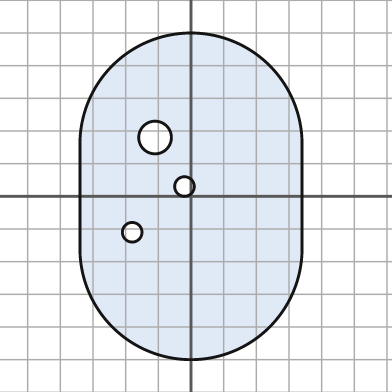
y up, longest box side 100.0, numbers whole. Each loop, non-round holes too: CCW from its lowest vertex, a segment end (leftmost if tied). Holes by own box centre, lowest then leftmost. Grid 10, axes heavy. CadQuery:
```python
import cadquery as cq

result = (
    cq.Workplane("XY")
    .moveTo(-34.0, -16.0)
    .threePointArc((0.0, -50.0), (34.0, -16.0))
    .lineTo(34.0, 16.0)
    .threePointArc((0.0, 50.0), (-34.0, 16.0))
    .close()
    .moveTo(-18.0, -11.0)
    .circle(3.0)
    .moveTo(-2.0, 3.0)
    .circle(3.0)
    .moveTo(-11.0, 18.0)
    .circle(5.0)
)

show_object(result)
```